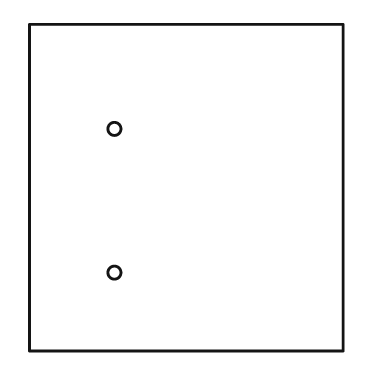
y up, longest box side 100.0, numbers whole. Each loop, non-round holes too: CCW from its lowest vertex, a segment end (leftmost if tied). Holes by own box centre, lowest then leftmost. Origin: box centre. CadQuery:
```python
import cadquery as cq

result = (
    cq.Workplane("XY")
    .moveTo(-48.0, -50.0)
    .lineTo(48.0, -50.0)
    .lineTo(48.0, 50.0)
    .lineTo(-48.0, 50.0)
    .close()
    .moveTo(-22.0, -26.0)
    .circle(2.0)
    .moveTo(-22.0, 18.0)
    .circle(2.0)
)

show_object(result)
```